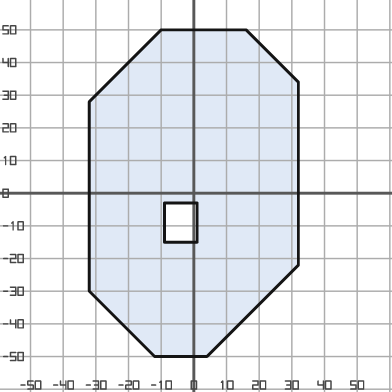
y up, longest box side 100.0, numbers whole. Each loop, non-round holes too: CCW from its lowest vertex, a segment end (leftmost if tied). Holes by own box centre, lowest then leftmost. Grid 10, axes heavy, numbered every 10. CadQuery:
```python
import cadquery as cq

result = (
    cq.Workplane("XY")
    .moveTo(-12.0, -50.0)
    .lineTo(4.0, -50.0)
    .lineTo(32.0, -22.0)
    .lineTo(32.0, 34.0)
    .lineTo(16.0, 50.0)
    .lineTo(-10.0, 50.0)
    .lineTo(-32.0, 28.0)
    .lineTo(-32.0, -30.0)
    .close()
    .moveTo(-9.0, -15.0)
    .lineTo(1.0, -15.0)
    .lineTo(1.0, -3.0)
    .lineTo(-9.0, -3.0)
    .close()
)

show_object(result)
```